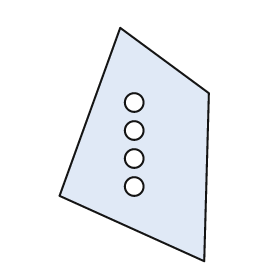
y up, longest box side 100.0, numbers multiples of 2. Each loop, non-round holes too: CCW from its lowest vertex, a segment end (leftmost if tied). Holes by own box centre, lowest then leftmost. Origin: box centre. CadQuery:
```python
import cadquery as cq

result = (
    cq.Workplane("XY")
    .moveTo(30.0, -50.0)
    .lineTo(32.0, 22.0)
    .lineTo(-6.0, 50.0)
    .lineTo(-32.0, -22.0)
    .close()
    .moveTo(0.0, -18.0)
    .circle(4.0)
    .moveTo(0.0, -6.0)
    .circle(4.0)
    .moveTo(0.0, 6.0)
    .circle(4.0)
    .moveTo(0.0, 18.0)
    .circle(4.0)
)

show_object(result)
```